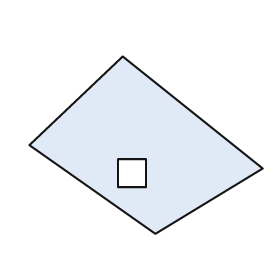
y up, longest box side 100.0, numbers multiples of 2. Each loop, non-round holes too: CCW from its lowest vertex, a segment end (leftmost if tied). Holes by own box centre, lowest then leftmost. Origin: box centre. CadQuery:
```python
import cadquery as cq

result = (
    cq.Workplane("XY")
    .moveTo(4.0, -38.0)
    .lineTo(50.0, -10.0)
    .lineTo(-10.0, 38.0)
    .lineTo(-50.0, 0.0)
    .close()
    .moveTo(-12.0, -18.0)
    .lineTo(0.0, -18.0)
    .lineTo(0.0, -6.0)
    .lineTo(-12.0, -6.0)
    .close()
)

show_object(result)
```